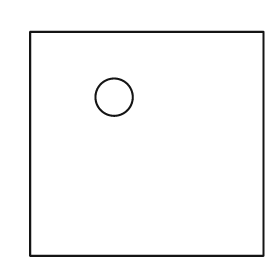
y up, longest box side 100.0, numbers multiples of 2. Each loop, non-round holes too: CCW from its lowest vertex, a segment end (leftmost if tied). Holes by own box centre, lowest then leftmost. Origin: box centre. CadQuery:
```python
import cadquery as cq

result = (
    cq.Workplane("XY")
    .moveTo(-50.0, -48.0)
    .lineTo(50.0, -48.0)
    .lineTo(50.0, 48.0)
    .lineTo(-50.0, 48.0)
    .close()
    .moveTo(-14.0, 20.0)
    .circle(8.0)
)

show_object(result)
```